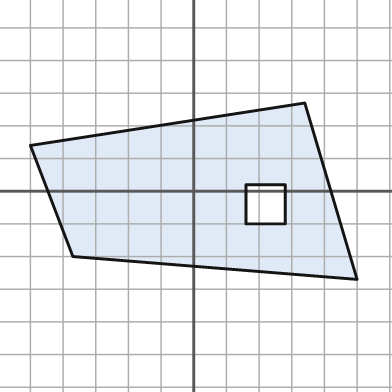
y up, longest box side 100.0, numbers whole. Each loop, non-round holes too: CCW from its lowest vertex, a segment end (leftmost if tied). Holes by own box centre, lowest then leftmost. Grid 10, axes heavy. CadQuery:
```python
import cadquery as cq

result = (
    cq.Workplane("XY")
    .moveTo(50.0, -27.0)
    .lineTo(34.0, 27.0)
    .lineTo(-50.0, 14.0)
    .lineTo(-37.0, -20.0)
    .close()
    .moveTo(16.0, -10.0)
    .lineTo(28.0, -10.0)
    .lineTo(28.0, 2.0)
    .lineTo(16.0, 2.0)
    .close()
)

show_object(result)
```